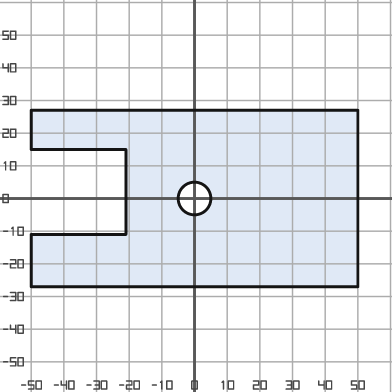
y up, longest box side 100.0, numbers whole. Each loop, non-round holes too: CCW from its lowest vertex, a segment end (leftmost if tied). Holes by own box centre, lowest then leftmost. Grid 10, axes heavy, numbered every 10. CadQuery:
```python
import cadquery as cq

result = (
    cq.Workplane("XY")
    .moveTo(-50.0, -27.0)
    .lineTo(50.0, -27.0)
    .lineTo(50.0, 27.0)
    .lineTo(-50.0, 27.0)
    .lineTo(-50.0, 15.0)
    .lineTo(-21.0, 15.0)
    .lineTo(-21.0, -11.0)
    .lineTo(-50.0, -11.0)
    .close()
    .moveTo(0.0, 0.0)
    .circle(5.0)
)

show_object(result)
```